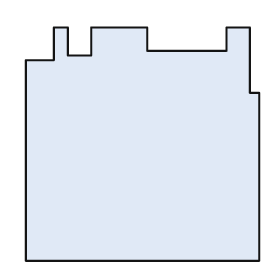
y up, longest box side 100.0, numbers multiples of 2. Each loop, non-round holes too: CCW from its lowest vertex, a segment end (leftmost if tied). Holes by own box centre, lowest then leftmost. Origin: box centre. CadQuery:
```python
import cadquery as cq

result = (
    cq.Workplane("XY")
    .moveTo(-50.0, -50.0)
    .lineTo(50.0, -50.0)
    .lineTo(50.0, 22.0)
    .lineTo(46.0, 22.0)
    .lineTo(46.0, 50.0)
    .lineTo(36.0, 50.0)
    .lineTo(36.0, 40.0)
    .lineTo(2.0, 40.0)
    .lineTo(2.0, 50.0)
    .lineTo(-22.0, 50.0)
    .lineTo(-22.0, 38.0)
    .lineTo(-32.0, 38.0)
    .lineTo(-32.0, 50.0)
    .lineTo(-38.0, 50.0)
    .lineTo(-38.0, 36.0)
    .lineTo(-50.0, 36.0)
    .close()
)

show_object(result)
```